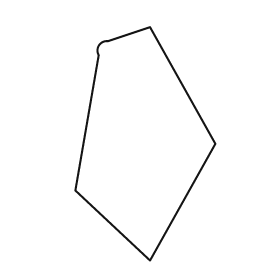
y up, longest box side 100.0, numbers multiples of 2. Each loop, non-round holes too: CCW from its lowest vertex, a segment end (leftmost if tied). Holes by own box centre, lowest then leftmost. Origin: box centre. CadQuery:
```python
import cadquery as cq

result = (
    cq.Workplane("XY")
    .moveTo(2.0, -50.0)
    .lineTo(30.0, 0.0)
    .lineTo(2.0, 50.0)
    .lineTo(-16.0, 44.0)
    .threePointArc((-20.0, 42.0), (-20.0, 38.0))
    .lineTo(-30.0, -20.0)
    .close()
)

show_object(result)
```